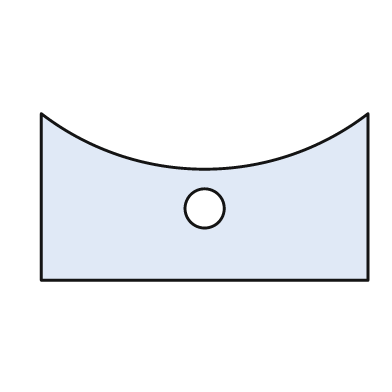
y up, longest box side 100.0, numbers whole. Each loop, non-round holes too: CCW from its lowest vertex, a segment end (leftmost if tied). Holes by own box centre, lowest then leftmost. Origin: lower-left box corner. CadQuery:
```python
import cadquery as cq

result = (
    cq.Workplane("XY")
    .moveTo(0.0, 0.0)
    .lineTo(100.0, 0.0)
    .lineTo(100.0, 51.0)
    .threePointArc((50.0, 34.0), (0.0, 51.0))
    .close()
    .moveTo(50.0, 22.0)
    .circle(6.0)
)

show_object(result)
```